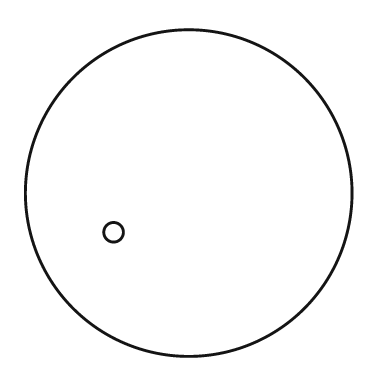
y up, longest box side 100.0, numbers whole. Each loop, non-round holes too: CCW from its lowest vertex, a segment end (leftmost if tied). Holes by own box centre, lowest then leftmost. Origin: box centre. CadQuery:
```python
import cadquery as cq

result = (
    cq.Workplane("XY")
    .moveTo(0.0, 0.0)
    .circle(50.0)
    .moveTo(-23.0, -12.0)
    .circle(3.0)
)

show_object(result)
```